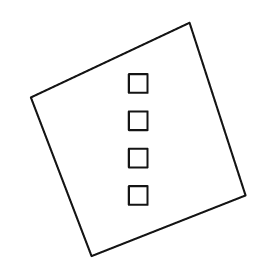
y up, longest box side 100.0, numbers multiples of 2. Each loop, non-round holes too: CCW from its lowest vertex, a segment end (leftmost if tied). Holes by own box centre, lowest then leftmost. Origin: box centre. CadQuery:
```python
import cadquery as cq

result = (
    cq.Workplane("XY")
    .moveTo(-20.0, -50.0)
    .lineTo(46.0, -24.0)
    .lineTo(22.0, 50.0)
    .lineTo(-46.0, 18.0)
    .close()
    .moveTo(-4.0, -28.0)
    .lineTo(4.0, -28.0)
    .lineTo(4.0, -20.0)
    .lineTo(-4.0, -20.0)
    .close()
    .moveTo(-4.0, -12.0)
    .lineTo(4.0, -12.0)
    .lineTo(4.0, -4.0)
    .lineTo(-4.0, -4.0)
    .close()
    .moveTo(-4.0, 4.0)
    .lineTo(4.0, 4.0)
    .lineTo(4.0, 12.0)
    .lineTo(-4.0, 12.0)
    .close()
    .moveTo(-4.0, 20.0)
    .lineTo(4.0, 20.0)
    .lineTo(4.0, 28.0)
    .lineTo(-4.0, 28.0)
    .close()
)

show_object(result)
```